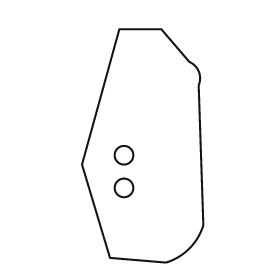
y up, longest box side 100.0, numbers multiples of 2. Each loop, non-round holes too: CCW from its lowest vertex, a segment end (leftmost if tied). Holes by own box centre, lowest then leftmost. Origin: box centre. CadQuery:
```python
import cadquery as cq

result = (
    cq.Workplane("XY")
    .moveTo(10.0, -50.0)
    .threePointArc((20.0, -44.0), (26.0, -34.0))
    .lineTo(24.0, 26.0)
    .threePointArc((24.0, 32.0), (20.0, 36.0))
    .lineTo(8.0, 50.0)
    .lineTo(-10.0, 50.0)
    .lineTo(-26.0, -8.0)
    .lineTo(-14.0, -48.0)
    .close()
    .moveTo(-8.0, -18.0)
    .circle(4.0)
    .moveTo(-8.0, -4.0)
    .circle(4.0)
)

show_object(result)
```